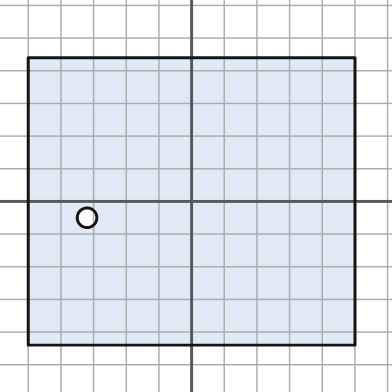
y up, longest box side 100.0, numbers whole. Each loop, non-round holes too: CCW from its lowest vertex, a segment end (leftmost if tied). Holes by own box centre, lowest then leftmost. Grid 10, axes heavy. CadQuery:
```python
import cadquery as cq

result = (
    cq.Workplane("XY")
    .moveTo(-50.0, -44.0)
    .lineTo(50.0, -44.0)
    .lineTo(50.0, 44.0)
    .lineTo(-50.0, 44.0)
    .close()
    .moveTo(-32.0, -5.0)
    .circle(3.0)
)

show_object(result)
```